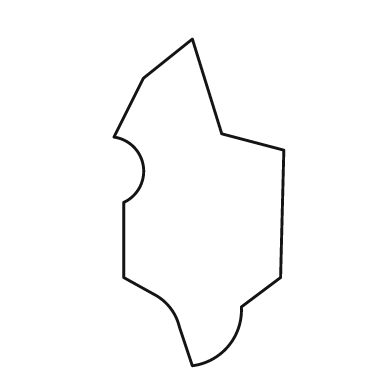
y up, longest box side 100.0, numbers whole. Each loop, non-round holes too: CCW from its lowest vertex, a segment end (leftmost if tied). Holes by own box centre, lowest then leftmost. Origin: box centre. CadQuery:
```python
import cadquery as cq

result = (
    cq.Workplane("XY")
    .moveTo(-2.0, -50.0)
    .threePointArc((9.0, -44.0), (13.0, -32.0))
    .lineTo(25.0, -23.0)
    .lineTo(26.0, 16.0)
    .lineTo(7.0, 21.0)
    .lineTo(-2.0, 50.0)
    .lineTo(-17.0, 38.0)
    .lineTo(-26.0, 20.0)
    .threePointArc((-17.0, 11.0), (-23.0, 0.0))
    .lineTo(-23.0, -23.0)
    .lineTo(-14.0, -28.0)
    .threePointArc((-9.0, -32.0), (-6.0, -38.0))
    .close()
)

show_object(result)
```